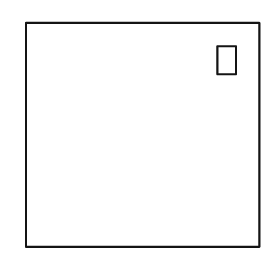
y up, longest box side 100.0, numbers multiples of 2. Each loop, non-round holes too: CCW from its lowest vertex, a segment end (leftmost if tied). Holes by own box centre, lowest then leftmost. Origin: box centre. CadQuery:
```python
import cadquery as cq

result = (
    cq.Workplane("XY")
    .moveTo(-50.0, -48.0)
    .lineTo(50.0, -48.0)
    .lineTo(50.0, 48.0)
    .lineTo(-50.0, 48.0)
    .close()
    .moveTo(32.0, 26.0)
    .lineTo(40.0, 26.0)
    .lineTo(40.0, 38.0)
    .lineTo(32.0, 38.0)
    .close()
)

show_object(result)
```